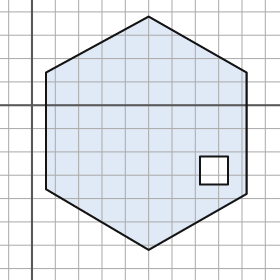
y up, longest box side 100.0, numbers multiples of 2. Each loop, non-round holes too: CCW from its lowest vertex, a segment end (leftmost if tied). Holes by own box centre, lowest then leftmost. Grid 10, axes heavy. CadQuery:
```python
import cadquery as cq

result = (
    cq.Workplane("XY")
    .moveTo(50.0, -62.0)
    .lineTo(92.0, -38.0)
    .lineTo(92.0, 14.0)
    .lineTo(50.0, 38.0)
    .lineTo(6.0, 14.0)
    .lineTo(6.0, -36.0)
    .close()
    .moveTo(72.0, -34.0)
    .lineTo(84.0, -34.0)
    .lineTo(84.0, -22.0)
    .lineTo(72.0, -22.0)
    .close()
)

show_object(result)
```